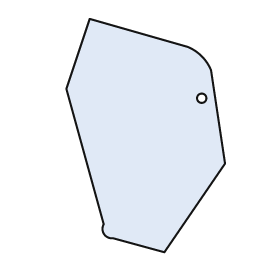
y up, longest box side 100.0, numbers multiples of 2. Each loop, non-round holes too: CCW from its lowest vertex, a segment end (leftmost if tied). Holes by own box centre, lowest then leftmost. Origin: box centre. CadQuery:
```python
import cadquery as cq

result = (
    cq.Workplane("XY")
    .moveTo(8.0, -50.0)
    .lineTo(34.0, -12.0)
    .lineTo(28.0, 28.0)
    .threePointArc((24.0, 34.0), (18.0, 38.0))
    .lineTo(-24.0, 50.0)
    .lineTo(-34.0, 20.0)
    .lineTo(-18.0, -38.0)
    .threePointArc((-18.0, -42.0), (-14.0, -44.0))
    .close()
    .moveTo(24.0, 16.0)
    .circle(2.0)
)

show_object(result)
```